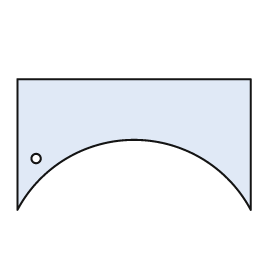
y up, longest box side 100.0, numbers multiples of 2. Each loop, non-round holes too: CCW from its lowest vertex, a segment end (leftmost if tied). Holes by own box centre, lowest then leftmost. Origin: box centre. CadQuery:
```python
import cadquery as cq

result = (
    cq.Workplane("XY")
    .moveTo(-50.0, -28.0)
    .threePointArc((0.0, 2.0), (50.0, -28.0))
    .lineTo(50.0, 28.0)
    .lineTo(-50.0, 28.0)
    .close()
    .moveTo(-42.0, -6.0)
    .circle(2.0)
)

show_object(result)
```